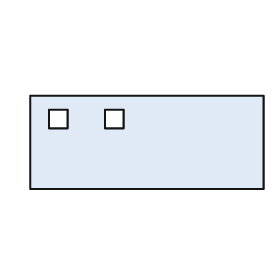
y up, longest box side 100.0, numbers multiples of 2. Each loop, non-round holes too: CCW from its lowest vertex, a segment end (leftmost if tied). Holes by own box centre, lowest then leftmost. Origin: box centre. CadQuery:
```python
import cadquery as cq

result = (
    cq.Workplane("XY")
    .moveTo(-50.0, -20.0)
    .lineTo(50.0, -20.0)
    .lineTo(50.0, 20.0)
    .lineTo(-50.0, 20.0)
    .close()
    .moveTo(-42.0, 6.0)
    .lineTo(-34.0, 6.0)
    .lineTo(-34.0, 14.0)
    .lineTo(-42.0, 14.0)
    .close()
    .moveTo(-18.0, 6.0)
    .lineTo(-10.0, 6.0)
    .lineTo(-10.0, 14.0)
    .lineTo(-18.0, 14.0)
    .close()
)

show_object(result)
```